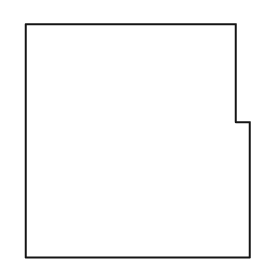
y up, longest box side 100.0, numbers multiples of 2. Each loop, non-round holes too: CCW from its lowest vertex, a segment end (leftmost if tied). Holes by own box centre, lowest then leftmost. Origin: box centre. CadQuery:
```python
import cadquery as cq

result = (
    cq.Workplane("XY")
    .moveTo(-48.0, -50.0)
    .lineTo(48.0, -50.0)
    .lineTo(48.0, 8.0)
    .lineTo(42.0, 8.0)
    .lineTo(42.0, 50.0)
    .lineTo(-48.0, 50.0)
    .close()
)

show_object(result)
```